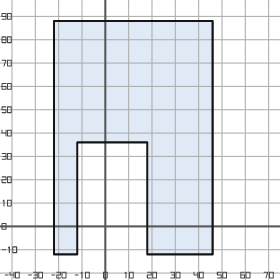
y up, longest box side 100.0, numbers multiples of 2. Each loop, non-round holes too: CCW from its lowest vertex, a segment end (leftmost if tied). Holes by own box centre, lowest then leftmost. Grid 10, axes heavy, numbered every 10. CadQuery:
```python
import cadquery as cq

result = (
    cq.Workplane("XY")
    .moveTo(-22.0, -12.0)
    .lineTo(-12.0, -12.0)
    .lineTo(-12.0, 36.0)
    .lineTo(18.0, 36.0)
    .lineTo(18.0, -12.0)
    .lineTo(46.0, -12.0)
    .lineTo(46.0, 88.0)
    .lineTo(-22.0, 88.0)
    .close()
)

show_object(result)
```